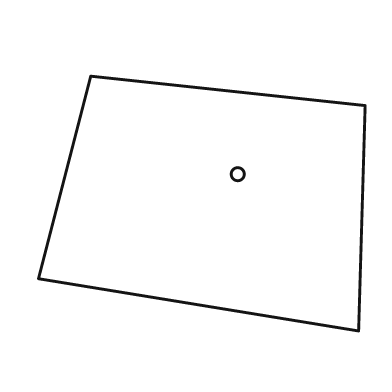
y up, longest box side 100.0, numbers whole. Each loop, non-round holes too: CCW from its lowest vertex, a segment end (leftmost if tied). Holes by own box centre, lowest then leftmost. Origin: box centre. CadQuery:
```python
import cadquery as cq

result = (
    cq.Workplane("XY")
    .moveTo(48.0, -39.0)
    .lineTo(50.0, 30.0)
    .lineTo(-34.0, 39.0)
    .lineTo(-50.0, -23.0)
    .close()
    .moveTo(11.0, 9.0)
    .circle(2.0)
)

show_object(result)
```